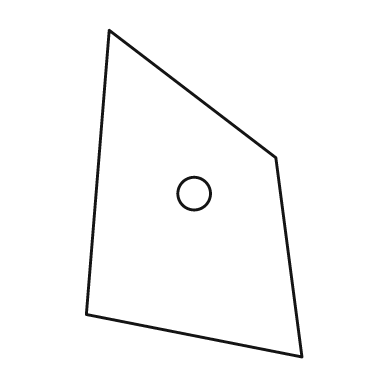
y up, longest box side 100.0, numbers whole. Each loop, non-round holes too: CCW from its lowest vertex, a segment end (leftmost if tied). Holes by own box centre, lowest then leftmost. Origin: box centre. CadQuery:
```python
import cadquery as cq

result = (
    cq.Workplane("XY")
    .moveTo(33.0, -50.0)
    .lineTo(25.0, 11.0)
    .lineTo(-26.0, 50.0)
    .lineTo(-33.0, -37.0)
    .close()
    .moveTo(0.0, 0.0)
    .circle(5.0)
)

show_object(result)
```